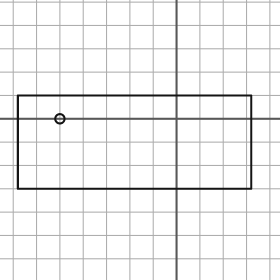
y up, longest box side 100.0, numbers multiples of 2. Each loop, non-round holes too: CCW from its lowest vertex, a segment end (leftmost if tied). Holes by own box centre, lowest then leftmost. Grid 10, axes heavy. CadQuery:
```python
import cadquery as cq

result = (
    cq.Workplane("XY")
    .moveTo(-68.0, -30.0)
    .lineTo(32.0, -30.0)
    .lineTo(32.0, 10.0)
    .lineTo(-68.0, 10.0)
    .close()
    .moveTo(-50.0, 0.0)
    .circle(2.0)
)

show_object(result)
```